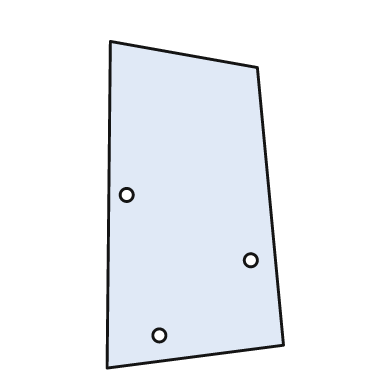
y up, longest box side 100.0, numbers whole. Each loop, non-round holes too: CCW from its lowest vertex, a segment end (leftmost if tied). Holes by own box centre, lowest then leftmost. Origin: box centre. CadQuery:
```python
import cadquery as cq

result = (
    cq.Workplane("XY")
    .moveTo(-27.0, -50.0)
    .lineTo(27.0, -43.0)
    .lineTo(19.0, 42.0)
    .lineTo(-26.0, 50.0)
    .close()
    .moveTo(-11.0, -40.0)
    .circle(2.0)
    .moveTo(17.0, -17.0)
    .circle(2.0)
    .moveTo(-21.0, 3.0)
    .circle(2.0)
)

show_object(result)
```